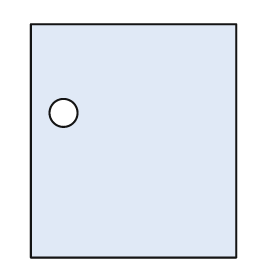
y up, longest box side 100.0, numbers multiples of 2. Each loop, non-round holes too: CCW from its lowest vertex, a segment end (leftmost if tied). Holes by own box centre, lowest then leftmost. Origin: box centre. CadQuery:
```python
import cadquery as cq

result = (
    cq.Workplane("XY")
    .moveTo(-44.0, -50.0)
    .lineTo(44.0, -50.0)
    .lineTo(44.0, 50.0)
    .lineTo(-44.0, 50.0)
    .close()
    .moveTo(-30.0, 12.0)
    .circle(6.0)
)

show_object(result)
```